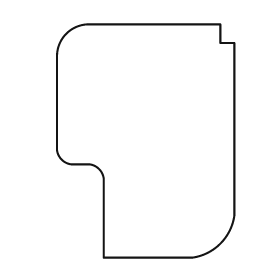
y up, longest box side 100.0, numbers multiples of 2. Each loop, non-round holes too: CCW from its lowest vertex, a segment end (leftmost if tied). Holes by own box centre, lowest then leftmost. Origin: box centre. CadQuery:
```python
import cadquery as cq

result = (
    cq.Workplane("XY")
    .moveTo(-18.0, -50.0)
    .lineTo(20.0, -50.0)
    .threePointArc((32.0, -44.0), (38.0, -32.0))
    .lineTo(38.0, 42.0)
    .lineTo(32.0, 42.0)
    .lineTo(32.0, 50.0)
    .lineTo(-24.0, 50.0)
    .threePointArc((-34.0, 46.0), (-38.0, 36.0))
    .lineTo(-38.0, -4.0)
    .threePointArc((-36.0, -8.0), (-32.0, -10.0))
    .lineTo(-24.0, -10.0)
    .threePointArc((-20.0, -12.0), (-18.0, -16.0))
    .close()
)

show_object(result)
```